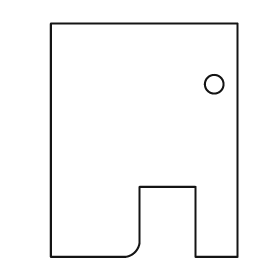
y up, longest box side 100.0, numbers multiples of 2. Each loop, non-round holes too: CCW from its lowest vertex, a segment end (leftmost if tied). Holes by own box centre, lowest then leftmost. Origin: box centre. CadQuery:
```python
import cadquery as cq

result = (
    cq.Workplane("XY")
    .moveTo(-40.0, -50.0)
    .lineTo(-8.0, -50.0)
    .threePointArc((-4.0, -48.0), (-2.0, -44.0))
    .lineTo(-2.0, -20.0)
    .lineTo(22.0, -20.0)
    .lineTo(22.0, -50.0)
    .lineTo(40.0, -50.0)
    .lineTo(40.0, 50.0)
    .lineTo(-40.0, 50.0)
    .close()
    .moveTo(30.0, 24.0)
    .circle(4.0)
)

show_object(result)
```